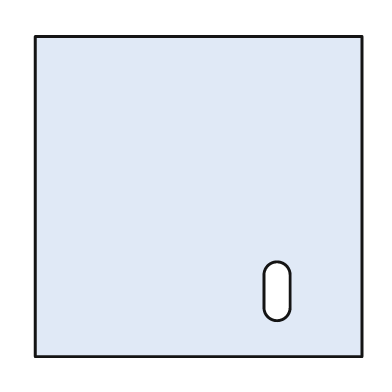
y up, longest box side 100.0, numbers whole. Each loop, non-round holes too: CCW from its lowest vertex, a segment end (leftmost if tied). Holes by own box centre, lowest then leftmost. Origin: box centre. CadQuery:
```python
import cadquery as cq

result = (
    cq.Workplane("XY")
    .moveTo(-50.0, -49.0)
    .lineTo(50.0, -49.0)
    .lineTo(50.0, 49.0)
    .lineTo(-50.0, 49.0)
    .close()
    .moveTo(20.0, -34.0)
    .threePointArc((24.0, -38.0), (28.0, -34.0))
    .lineTo(28.0, -24.0)
    .threePointArc((24.0, -20.0), (20.0, -24.0))
    .close()
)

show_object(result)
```